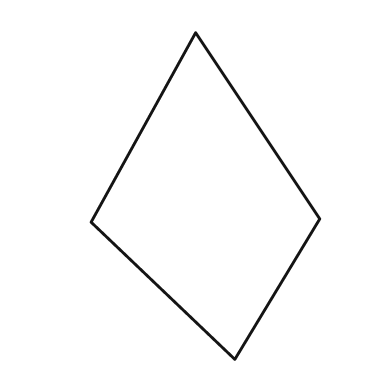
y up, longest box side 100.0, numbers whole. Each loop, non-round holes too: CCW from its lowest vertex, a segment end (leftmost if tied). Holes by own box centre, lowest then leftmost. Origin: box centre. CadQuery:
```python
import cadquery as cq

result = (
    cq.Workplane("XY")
    .moveTo(9.0, -50.0)
    .lineTo(35.0, -7.0)
    .lineTo(-3.0, 50.0)
    .lineTo(-35.0, -8.0)
    .close()
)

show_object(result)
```